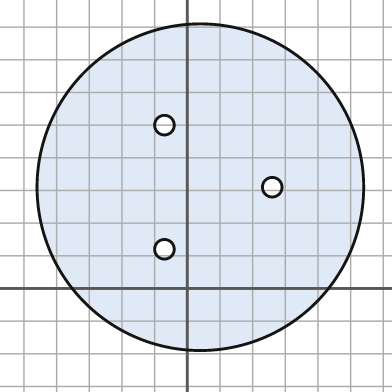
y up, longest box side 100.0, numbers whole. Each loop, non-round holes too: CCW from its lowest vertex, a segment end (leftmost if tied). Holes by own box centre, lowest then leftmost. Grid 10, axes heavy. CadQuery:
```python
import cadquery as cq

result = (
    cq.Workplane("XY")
    .moveTo(4.0, 31.0)
    .circle(50.0)
    .moveTo(-7.0, 12.0)
    .circle(3.0)
    .moveTo(26.0, 31.0)
    .circle(3.0)
    .moveTo(-7.0, 50.0)
    .circle(3.0)
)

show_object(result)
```